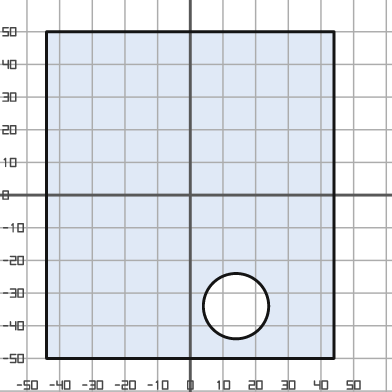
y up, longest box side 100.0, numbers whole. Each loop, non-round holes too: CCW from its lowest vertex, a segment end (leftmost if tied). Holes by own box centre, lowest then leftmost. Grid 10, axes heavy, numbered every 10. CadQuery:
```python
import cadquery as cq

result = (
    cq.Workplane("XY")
    .moveTo(-44.0, -50.0)
    .lineTo(44.0, -50.0)
    .lineTo(44.0, 50.0)
    .lineTo(-44.0, 50.0)
    .close()
    .moveTo(14.0, -34.0)
    .circle(10.0)
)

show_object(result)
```